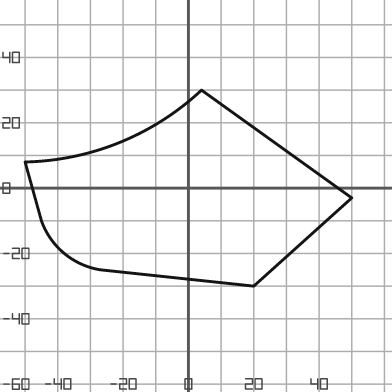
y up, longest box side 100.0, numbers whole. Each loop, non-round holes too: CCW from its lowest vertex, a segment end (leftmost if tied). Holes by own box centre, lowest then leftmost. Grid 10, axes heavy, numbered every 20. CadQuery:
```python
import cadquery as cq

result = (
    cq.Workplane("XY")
    .moveTo(20.0, -30.0)
    .lineTo(50.0, -3.0)
    .lineTo(4.0, 30.0)
    .threePointArc((-21.0, 14.0), (-50.0, 8.0))
    .lineTo(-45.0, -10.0)
    .threePointArc((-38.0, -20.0), (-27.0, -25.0))
    .close()
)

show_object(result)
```